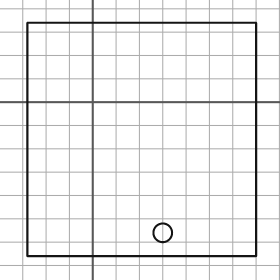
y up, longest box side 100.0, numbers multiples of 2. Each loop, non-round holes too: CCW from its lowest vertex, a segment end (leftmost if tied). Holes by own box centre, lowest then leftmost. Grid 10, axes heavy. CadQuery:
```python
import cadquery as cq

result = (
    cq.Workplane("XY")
    .moveTo(-28.0, -66.0)
    .lineTo(70.0, -66.0)
    .lineTo(70.0, 34.0)
    .lineTo(-28.0, 34.0)
    .close()
    .moveTo(30.0, -56.0)
    .circle(4.0)
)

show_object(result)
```